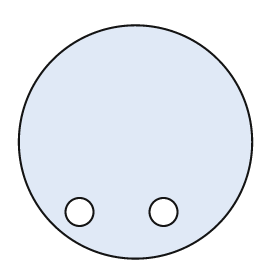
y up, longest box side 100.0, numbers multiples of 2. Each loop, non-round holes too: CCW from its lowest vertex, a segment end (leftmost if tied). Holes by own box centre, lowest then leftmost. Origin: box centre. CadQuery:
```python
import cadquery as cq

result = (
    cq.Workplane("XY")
    .moveTo(0.0, 0.0)
    .circle(50.0)
    .moveTo(-24.0, -30.0)
    .circle(6.0)
    .moveTo(12.0, -30.0)
    .circle(6.0)
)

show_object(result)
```